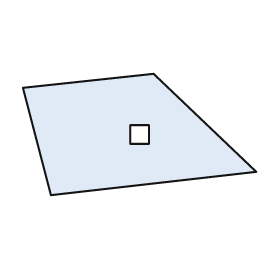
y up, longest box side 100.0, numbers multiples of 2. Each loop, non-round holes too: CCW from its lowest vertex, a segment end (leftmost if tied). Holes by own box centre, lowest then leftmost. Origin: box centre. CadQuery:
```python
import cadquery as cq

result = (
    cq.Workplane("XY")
    .moveTo(-38.0, -26.0)
    .lineTo(50.0, -16.0)
    .lineTo(6.0, 26.0)
    .lineTo(-50.0, 20.0)
    .close()
    .moveTo(-4.0, -4.0)
    .lineTo(4.0, -4.0)
    .lineTo(4.0, 4.0)
    .lineTo(-4.0, 4.0)
    .close()
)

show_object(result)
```